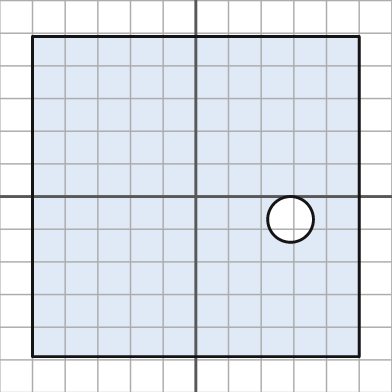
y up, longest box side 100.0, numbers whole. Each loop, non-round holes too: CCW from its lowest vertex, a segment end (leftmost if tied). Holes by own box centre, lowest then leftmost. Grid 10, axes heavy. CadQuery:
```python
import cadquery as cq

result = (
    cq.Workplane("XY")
    .moveTo(-50.0, -49.0)
    .lineTo(50.0, -49.0)
    .lineTo(50.0, 49.0)
    .lineTo(-50.0, 49.0)
    .close()
    .moveTo(29.0, -7.0)
    .circle(7.0)
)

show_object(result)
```